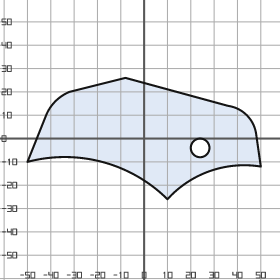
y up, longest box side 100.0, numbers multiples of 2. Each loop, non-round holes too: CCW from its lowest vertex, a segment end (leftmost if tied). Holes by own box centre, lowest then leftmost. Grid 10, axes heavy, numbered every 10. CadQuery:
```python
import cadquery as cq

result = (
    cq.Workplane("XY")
    .moveTo(10.0, -26.0)
    .threePointArc((28.0, -14.0), (50.0, -12.0))
    .lineTo(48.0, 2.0)
    .threePointArc((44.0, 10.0), (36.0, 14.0))
    .lineTo(-8.0, 26.0)
    .lineTo(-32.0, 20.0)
    .threePointArc((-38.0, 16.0), (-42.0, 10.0))
    .lineTo(-50.0, -10.0)
    .threePointArc((-18.0, -10.0), (10.0, -26.0))
    .close()
    .moveTo(24.0, -4.0)
    .circle(4.0)
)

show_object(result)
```